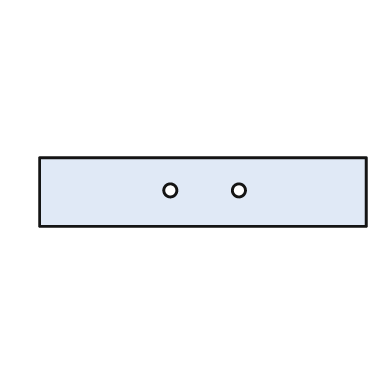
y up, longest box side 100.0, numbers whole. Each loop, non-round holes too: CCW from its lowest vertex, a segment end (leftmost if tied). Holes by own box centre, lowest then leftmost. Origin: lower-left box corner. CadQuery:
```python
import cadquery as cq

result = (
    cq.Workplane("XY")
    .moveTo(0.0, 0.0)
    .lineTo(100.0, 0.0)
    .lineTo(100.0, 21.0)
    .lineTo(0.0, 21.0)
    .close()
    .moveTo(40.0, 11.0)
    .circle(2.0)
    .moveTo(61.0, 11.0)
    .circle(2.0)
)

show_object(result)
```